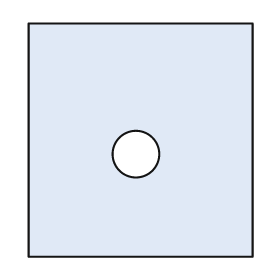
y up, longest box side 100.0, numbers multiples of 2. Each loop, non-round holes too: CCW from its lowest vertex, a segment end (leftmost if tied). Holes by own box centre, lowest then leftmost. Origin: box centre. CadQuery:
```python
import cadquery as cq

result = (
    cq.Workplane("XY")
    .moveTo(-48.0, -50.0)
    .lineTo(48.0, -50.0)
    .lineTo(48.0, 50.0)
    .lineTo(-48.0, 50.0)
    .close()
    .moveTo(-2.0, -6.0)
    .circle(10.0)
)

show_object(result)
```